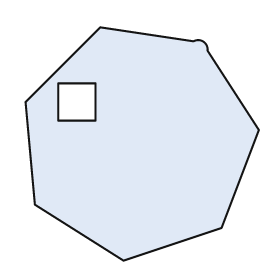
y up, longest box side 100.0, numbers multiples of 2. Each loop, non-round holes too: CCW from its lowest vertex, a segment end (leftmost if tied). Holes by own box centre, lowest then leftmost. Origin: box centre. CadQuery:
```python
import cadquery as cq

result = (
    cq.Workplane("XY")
    .moveTo(-8.0, -50.0)
    .lineTo(34.0, -36.0)
    .lineTo(50.0, 6.0)
    .lineTo(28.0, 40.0)
    .threePointArc((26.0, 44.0), (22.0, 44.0))
    .lineTo(-18.0, 50.0)
    .lineTo(-50.0, 18.0)
    .lineTo(-46.0, -26.0)
    .close()
    .moveTo(-36.0, 10.0)
    .lineTo(-20.0, 10.0)
    .lineTo(-20.0, 26.0)
    .lineTo(-36.0, 26.0)
    .close()
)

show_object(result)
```